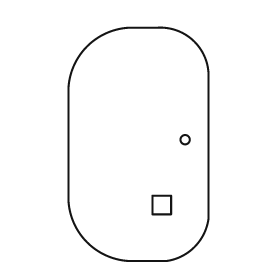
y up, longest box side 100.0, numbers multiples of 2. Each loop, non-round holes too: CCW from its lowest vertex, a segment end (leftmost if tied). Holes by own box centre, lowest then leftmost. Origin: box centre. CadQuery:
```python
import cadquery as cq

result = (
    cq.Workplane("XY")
    .moveTo(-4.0, -50.0)
    .lineTo(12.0, -50.0)
    .threePointArc((24.0, -44.0), (30.0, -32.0))
    .lineTo(30.0, 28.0)
    .threePointArc((24.0, 44.0), (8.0, 50.0))
    .lineTo(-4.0, 50.0)
    .threePointArc((-22.0, 42.0), (-30.0, 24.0))
    .lineTo(-30.0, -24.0)
    .threePointArc((-22.0, -42.0), (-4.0, -50.0))
    .close()
    .moveTo(6.0, -30.0)
    .lineTo(14.0, -30.0)
    .lineTo(14.0, -22.0)
    .lineTo(6.0, -22.0)
    .close()
    .moveTo(20.0, 2.0)
    .circle(2.0)
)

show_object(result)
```